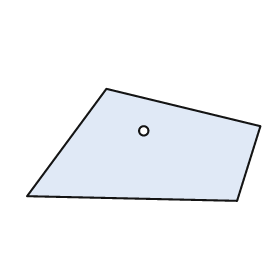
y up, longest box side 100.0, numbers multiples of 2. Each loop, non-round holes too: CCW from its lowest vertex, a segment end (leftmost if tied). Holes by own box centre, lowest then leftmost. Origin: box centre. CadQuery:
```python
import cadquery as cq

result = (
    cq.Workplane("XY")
    .moveTo(40.0, -24.0)
    .lineTo(50.0, 8.0)
    .lineTo(-16.0, 24.0)
    .lineTo(-50.0, -22.0)
    .close()
    .moveTo(0.0, 6.0)
    .circle(2.0)
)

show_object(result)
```